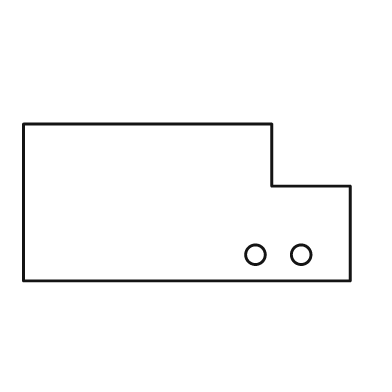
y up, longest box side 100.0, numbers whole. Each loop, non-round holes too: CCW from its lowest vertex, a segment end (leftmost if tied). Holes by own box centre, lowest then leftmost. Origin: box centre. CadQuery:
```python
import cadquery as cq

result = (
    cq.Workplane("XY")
    .moveTo(-50.0, -24.0)
    .lineTo(50.0, -24.0)
    .lineTo(50.0, 5.0)
    .lineTo(26.0, 5.0)
    .lineTo(26.0, 24.0)
    .lineTo(-50.0, 24.0)
    .close()
    .moveTo(21.0, -16.0)
    .circle(3.0)
    .moveTo(35.0, -16.0)
    .circle(3.0)
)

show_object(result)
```